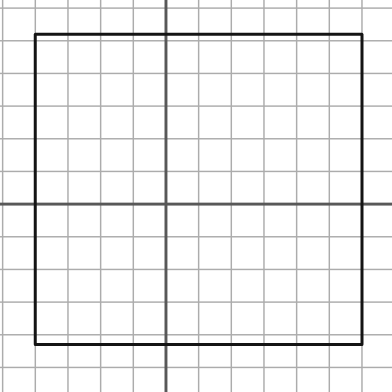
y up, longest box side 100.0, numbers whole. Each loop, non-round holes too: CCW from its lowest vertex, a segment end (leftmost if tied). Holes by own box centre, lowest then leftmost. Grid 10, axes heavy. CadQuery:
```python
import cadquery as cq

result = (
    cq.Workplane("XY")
    .moveTo(-40.0, -43.0)
    .lineTo(60.0, -43.0)
    .lineTo(60.0, 52.0)
    .lineTo(-40.0, 52.0)
    .close()
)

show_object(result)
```